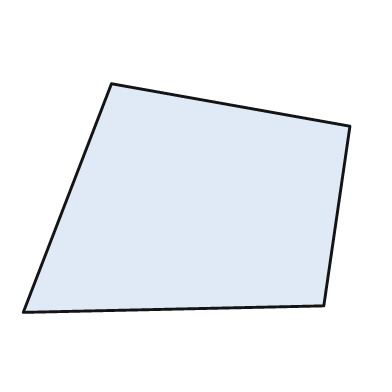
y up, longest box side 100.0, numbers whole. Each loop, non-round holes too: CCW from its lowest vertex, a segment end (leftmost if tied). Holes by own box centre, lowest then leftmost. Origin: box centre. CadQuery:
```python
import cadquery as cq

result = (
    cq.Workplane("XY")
    .moveTo(-50.0, -35.0)
    .lineTo(42.0, -33.0)
    .lineTo(50.0, 22.0)
    .lineTo(-23.0, 35.0)
    .close()
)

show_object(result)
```